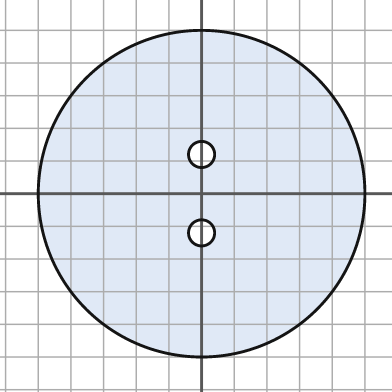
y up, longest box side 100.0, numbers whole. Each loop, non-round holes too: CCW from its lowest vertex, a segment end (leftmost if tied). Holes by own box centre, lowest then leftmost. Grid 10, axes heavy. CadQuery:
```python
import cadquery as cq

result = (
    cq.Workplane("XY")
    .moveTo(0.0, 0.0)
    .circle(50.0)
    .moveTo(0.0, -12.0)
    .circle(4.0)
    .moveTo(0.0, 12.0)
    .circle(4.0)
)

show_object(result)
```